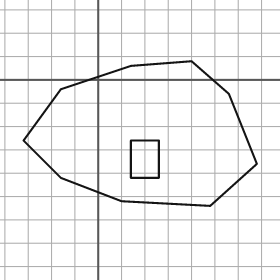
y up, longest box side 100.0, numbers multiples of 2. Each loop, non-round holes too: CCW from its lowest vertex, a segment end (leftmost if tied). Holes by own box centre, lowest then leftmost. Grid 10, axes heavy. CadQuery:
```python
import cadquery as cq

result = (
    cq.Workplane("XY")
    .moveTo(48.0, -54.0)
    .lineTo(68.0, -36.0)
    .lineTo(56.0, -6.0)
    .lineTo(40.0, 8.0)
    .lineTo(14.0, 6.0)
    .lineTo(-16.0, -4.0)
    .lineTo(-32.0, -26.0)
    .lineTo(-16.0, -42.0)
    .lineTo(10.0, -52.0)
    .close()
    .moveTo(14.0, -42.0)
    .lineTo(26.0, -42.0)
    .lineTo(26.0, -26.0)
    .lineTo(14.0, -26.0)
    .close()
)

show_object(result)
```